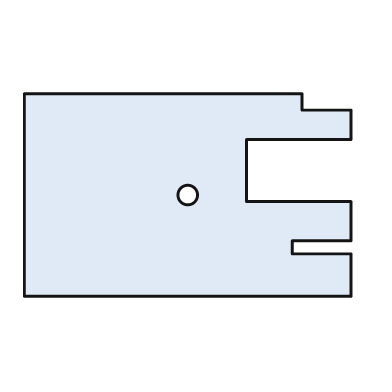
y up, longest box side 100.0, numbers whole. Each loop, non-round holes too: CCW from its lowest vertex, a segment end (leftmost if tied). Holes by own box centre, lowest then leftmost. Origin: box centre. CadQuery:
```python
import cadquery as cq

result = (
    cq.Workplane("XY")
    .moveTo(-50.0, -31.0)
    .lineTo(50.0, -31.0)
    .lineTo(50.0, -18.0)
    .lineTo(32.0, -18.0)
    .lineTo(32.0, -14.0)
    .lineTo(50.0, -14.0)
    .lineTo(50.0, -2.0)
    .lineTo(18.0, -2.0)
    .lineTo(18.0, 17.0)
    .lineTo(50.0, 17.0)
    .lineTo(50.0, 26.0)
    .lineTo(35.0, 26.0)
    .lineTo(35.0, 31.0)
    .lineTo(-50.0, 31.0)
    .close()
    .moveTo(0.0, 0.0)
    .circle(3.0)
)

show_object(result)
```